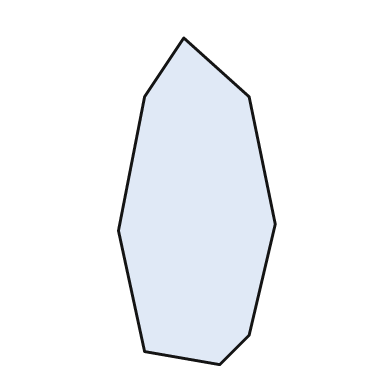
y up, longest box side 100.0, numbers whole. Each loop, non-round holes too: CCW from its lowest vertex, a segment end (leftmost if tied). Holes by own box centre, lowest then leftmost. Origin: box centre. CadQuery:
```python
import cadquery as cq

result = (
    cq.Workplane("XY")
    .moveTo(7.0, -50.0)
    .lineTo(16.0, -41.0)
    .lineTo(24.0, -7.0)
    .lineTo(16.0, 32.0)
    .lineTo(-4.0, 50.0)
    .lineTo(-16.0, 32.0)
    .lineTo(-24.0, -9.0)
    .lineTo(-16.0, -46.0)
    .close()
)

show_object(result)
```